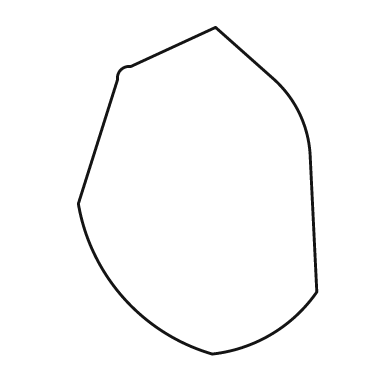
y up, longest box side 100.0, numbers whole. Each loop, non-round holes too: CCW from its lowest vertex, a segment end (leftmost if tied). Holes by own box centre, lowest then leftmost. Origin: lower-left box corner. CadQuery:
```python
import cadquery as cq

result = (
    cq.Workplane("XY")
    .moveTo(41.0, 0.0)
    .threePointArc((59.0, 6.0), (73.0, 19.0))
    .lineTo(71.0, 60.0)
    .threePointArc((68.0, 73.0), (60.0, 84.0))
    .lineTo(42.0, 100.0)
    .lineTo(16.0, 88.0)
    .threePointArc((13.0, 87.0), (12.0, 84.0))
    .lineTo(0.0, 46.0)
    .threePointArc((14.0, 17.0), (41.0, 0.0))
    .close()
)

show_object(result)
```